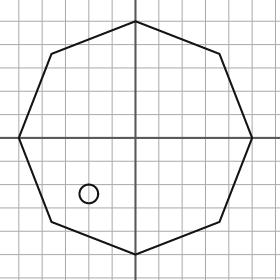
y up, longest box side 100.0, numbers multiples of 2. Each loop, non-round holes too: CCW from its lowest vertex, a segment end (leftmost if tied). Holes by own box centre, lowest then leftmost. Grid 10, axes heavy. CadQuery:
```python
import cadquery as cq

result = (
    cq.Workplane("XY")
    .moveTo(0.0, -50.0)
    .lineTo(36.0, -36.0)
    .lineTo(50.0, 0.0)
    .lineTo(36.0, 36.0)
    .lineTo(0.0, 50.0)
    .lineTo(-36.0, 36.0)
    .lineTo(-50.0, 0.0)
    .lineTo(-36.0, -36.0)
    .close()
    .moveTo(-20.0, -24.0)
    .circle(4.0)
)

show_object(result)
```